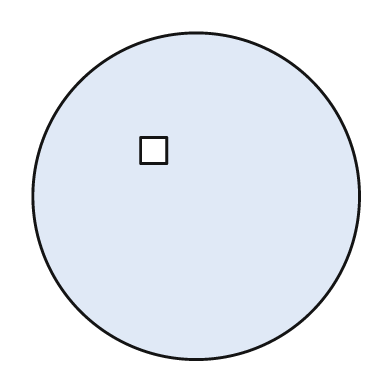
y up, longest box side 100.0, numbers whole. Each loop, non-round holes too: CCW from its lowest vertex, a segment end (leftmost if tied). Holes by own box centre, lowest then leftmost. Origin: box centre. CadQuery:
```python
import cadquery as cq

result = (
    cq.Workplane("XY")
    .moveTo(0.0, 0.0)
    .circle(50.0)
    .moveTo(-17.0, 10.0)
    .lineTo(-9.0, 10.0)
    .lineTo(-9.0, 18.0)
    .lineTo(-17.0, 18.0)
    .close()
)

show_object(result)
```